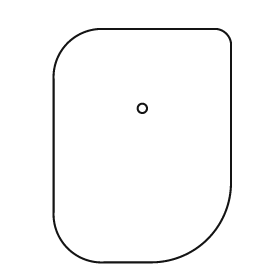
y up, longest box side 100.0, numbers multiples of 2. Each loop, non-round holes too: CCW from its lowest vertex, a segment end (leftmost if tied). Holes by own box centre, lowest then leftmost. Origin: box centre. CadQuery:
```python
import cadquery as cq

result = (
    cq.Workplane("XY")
    .moveTo(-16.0, -50.0)
    .lineTo(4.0, -50.0)
    .threePointArc((28.0, -40.0), (38.0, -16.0))
    .lineTo(38.0, 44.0)
    .threePointArc((36.0, 48.0), (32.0, 50.0))
    .lineTo(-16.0, 50.0)
    .threePointArc((-32.0, 44.0), (-38.0, 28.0))
    .lineTo(-38.0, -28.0)
    .threePointArc((-32.0, -44.0), (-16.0, -50.0))
    .close()
    .moveTo(0.0, 16.0)
    .circle(2.0)
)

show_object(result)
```